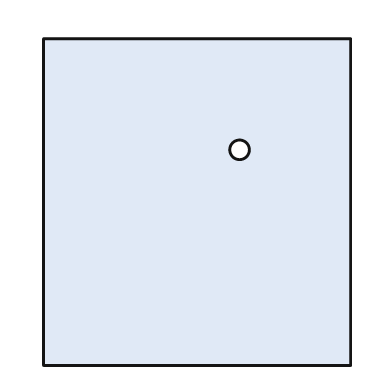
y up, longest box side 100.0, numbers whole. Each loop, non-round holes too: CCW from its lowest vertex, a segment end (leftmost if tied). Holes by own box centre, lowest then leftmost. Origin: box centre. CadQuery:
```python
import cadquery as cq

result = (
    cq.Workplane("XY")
    .moveTo(-47.0, -50.0)
    .lineTo(47.0, -50.0)
    .lineTo(47.0, 50.0)
    .lineTo(-47.0, 50.0)
    .close()
    .moveTo(13.0, 16.0)
    .circle(3.0)
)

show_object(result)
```